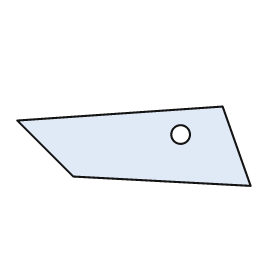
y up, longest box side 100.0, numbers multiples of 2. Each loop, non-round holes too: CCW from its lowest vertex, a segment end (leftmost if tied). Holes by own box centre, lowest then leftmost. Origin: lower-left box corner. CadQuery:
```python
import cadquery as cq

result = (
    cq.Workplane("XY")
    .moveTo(100.0, 0.0)
    .lineTo(88.0, 34.0)
    .lineTo(0.0, 28.0)
    .lineTo(24.0, 4.0)
    .close()
    .moveTo(70.0, 22.0)
    .circle(4.0)
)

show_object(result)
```